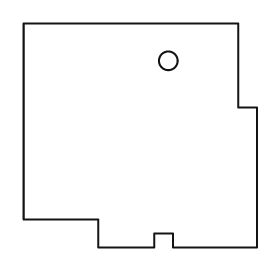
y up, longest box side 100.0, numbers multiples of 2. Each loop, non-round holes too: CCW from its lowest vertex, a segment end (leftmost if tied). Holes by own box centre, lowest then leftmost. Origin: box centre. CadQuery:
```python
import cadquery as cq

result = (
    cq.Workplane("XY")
    .moveTo(-18.0, -48.0)
    .lineTo(6.0, -48.0)
    .lineTo(6.0, -42.0)
    .lineTo(14.0, -42.0)
    .lineTo(14.0, -48.0)
    .lineTo(50.0, -48.0)
    .lineTo(50.0, 12.0)
    .lineTo(42.0, 12.0)
    .lineTo(42.0, 48.0)
    .lineTo(-50.0, 48.0)
    .lineTo(-50.0, -36.0)
    .lineTo(-18.0, -36.0)
    .close()
    .moveTo(12.0, 32.0)
    .circle(4.0)
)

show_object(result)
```